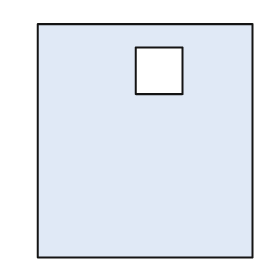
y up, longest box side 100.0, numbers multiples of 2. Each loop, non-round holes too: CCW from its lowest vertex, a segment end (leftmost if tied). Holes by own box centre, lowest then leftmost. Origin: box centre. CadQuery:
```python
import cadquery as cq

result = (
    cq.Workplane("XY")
    .moveTo(-46.0, -50.0)
    .lineTo(46.0, -50.0)
    .lineTo(46.0, 50.0)
    .lineTo(-46.0, 50.0)
    .close()
    .moveTo(-4.0, 20.0)
    .lineTo(16.0, 20.0)
    .lineTo(16.0, 40.0)
    .lineTo(-4.0, 40.0)
    .close()
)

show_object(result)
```